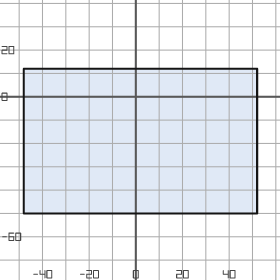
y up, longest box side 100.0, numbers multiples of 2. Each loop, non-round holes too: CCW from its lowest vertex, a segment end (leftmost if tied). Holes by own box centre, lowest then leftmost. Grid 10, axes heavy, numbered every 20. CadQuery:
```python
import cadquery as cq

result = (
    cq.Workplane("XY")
    .moveTo(-48.0, -50.0)
    .lineTo(52.0, -50.0)
    .lineTo(52.0, 12.0)
    .lineTo(-48.0, 12.0)
    .close()
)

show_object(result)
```